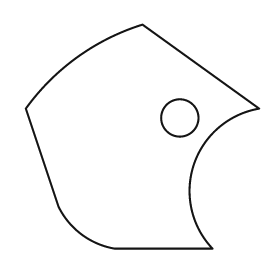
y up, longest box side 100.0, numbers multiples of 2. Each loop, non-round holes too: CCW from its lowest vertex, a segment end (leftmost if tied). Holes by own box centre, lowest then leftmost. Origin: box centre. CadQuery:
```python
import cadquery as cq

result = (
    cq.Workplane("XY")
    .moveTo(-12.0, -48.0)
    .lineTo(30.0, -48.0)
    .threePointArc((22.0, -12.0), (50.0, 12.0))
    .lineTo(0.0, 48.0)
    .threePointArc((-28.0, 34.0), (-50.0, 12.0))
    .lineTo(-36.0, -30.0)
    .threePointArc((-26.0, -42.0), (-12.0, -48.0))
    .close()
    .moveTo(16.0, 8.0)
    .circle(8.0)
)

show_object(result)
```